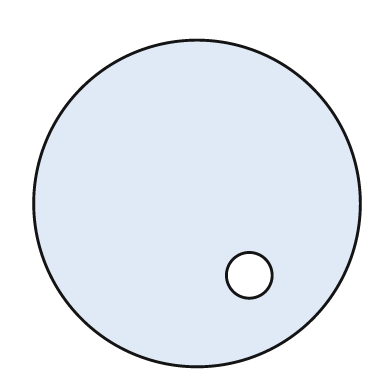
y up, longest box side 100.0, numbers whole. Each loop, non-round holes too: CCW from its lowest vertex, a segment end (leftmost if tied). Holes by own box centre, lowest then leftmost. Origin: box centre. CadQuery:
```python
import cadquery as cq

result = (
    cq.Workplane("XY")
    .moveTo(0.0, 0.0)
    .circle(50.0)
    .moveTo(16.0, -22.0)
    .circle(7.0)
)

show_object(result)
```